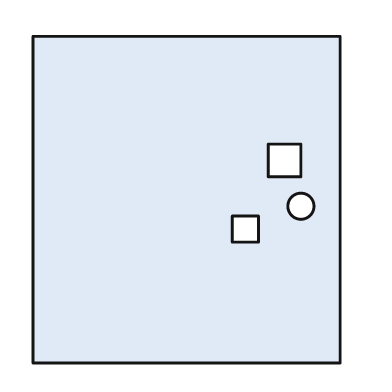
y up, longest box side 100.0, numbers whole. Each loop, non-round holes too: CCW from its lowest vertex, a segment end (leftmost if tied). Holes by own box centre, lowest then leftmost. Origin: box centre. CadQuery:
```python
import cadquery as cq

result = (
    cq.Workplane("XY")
    .moveTo(-47.0, -50.0)
    .lineTo(47.0, -50.0)
    .lineTo(47.0, 50.0)
    .lineTo(-47.0, 50.0)
    .close()
    .moveTo(14.0, -13.0)
    .lineTo(22.0, -13.0)
    .lineTo(22.0, -5.0)
    .lineTo(14.0, -5.0)
    .close()
    .moveTo(35.0, -2.0)
    .circle(4.0)
    .moveTo(25.0, 7.0)
    .lineTo(35.0, 7.0)
    .lineTo(35.0, 17.0)
    .lineTo(25.0, 17.0)
    .close()
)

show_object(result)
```